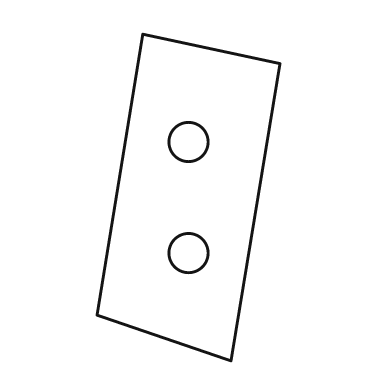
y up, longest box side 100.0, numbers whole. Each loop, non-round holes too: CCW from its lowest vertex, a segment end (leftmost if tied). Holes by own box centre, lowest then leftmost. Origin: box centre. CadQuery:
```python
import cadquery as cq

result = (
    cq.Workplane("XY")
    .moveTo(13.0, -50.0)
    .lineTo(28.0, 41.0)
    .lineTo(-14.0, 50.0)
    .lineTo(-28.0, -36.0)
    .close()
    .moveTo(0.0, -17.0)
    .circle(6.0)
    .moveTo(0.0, 17.0)
    .circle(6.0)
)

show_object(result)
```